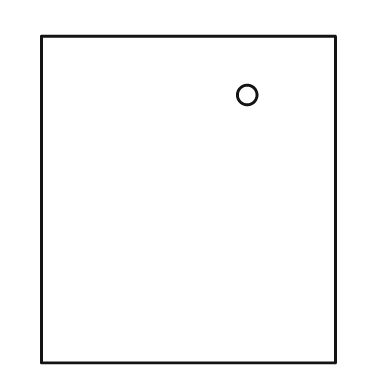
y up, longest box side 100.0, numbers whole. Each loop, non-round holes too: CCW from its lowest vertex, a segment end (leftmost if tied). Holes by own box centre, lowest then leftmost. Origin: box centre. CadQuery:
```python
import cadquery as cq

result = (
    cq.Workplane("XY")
    .moveTo(-45.0, -50.0)
    .lineTo(45.0, -50.0)
    .lineTo(45.0, 50.0)
    .lineTo(-45.0, 50.0)
    .close()
    .moveTo(18.0, 32.0)
    .circle(3.0)
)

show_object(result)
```